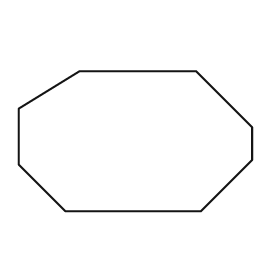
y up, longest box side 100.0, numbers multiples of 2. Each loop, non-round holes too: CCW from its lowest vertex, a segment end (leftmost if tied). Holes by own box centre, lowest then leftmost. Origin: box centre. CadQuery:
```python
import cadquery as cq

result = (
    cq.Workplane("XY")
    .moveTo(-30.0, -30.0)
    .lineTo(28.0, -30.0)
    .lineTo(50.0, -8.0)
    .lineTo(50.0, 6.0)
    .lineTo(26.0, 30.0)
    .lineTo(-24.0, 30.0)
    .lineTo(-50.0, 14.0)
    .lineTo(-50.0, -10.0)
    .close()
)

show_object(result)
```